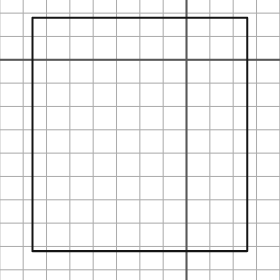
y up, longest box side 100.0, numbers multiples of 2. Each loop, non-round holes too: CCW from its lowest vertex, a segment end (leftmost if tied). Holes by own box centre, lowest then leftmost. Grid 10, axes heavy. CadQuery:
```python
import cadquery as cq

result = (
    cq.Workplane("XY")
    .moveTo(-66.0, -82.0)
    .lineTo(26.0, -82.0)
    .lineTo(26.0, 18.0)
    .lineTo(-66.0, 18.0)
    .close()
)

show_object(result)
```